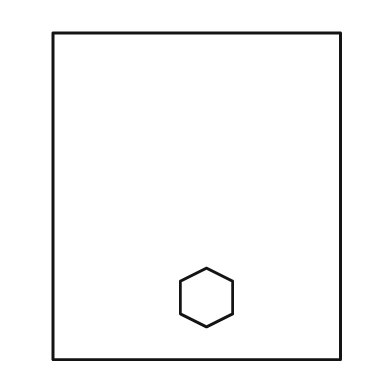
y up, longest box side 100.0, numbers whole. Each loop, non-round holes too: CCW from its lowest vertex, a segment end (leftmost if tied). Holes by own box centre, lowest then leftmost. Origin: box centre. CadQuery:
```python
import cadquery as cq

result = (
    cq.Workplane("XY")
    .moveTo(-44.0, -50.0)
    .lineTo(44.0, -50.0)
    .lineTo(44.0, 50.0)
    .lineTo(-44.0, 50.0)
    .close()
    .moveTo(3.0, -40.0)
    .lineTo(11.0, -36.0)
    .lineTo(11.0, -26.0)
    .lineTo(3.0, -22.0)
    .lineTo(-5.0, -26.0)
    .lineTo(-5.0, -36.0)
    .close()
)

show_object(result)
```